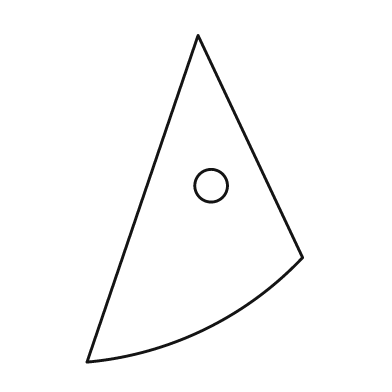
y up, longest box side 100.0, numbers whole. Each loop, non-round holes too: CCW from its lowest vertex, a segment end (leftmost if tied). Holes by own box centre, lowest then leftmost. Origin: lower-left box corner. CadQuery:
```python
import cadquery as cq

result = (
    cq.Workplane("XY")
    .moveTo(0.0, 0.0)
    .threePointArc((36.0, 10.0), (66.0, 32.0))
    .lineTo(34.0, 100.0)
    .close()
    .moveTo(38.0, 54.0)
    .circle(5.0)
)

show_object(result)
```